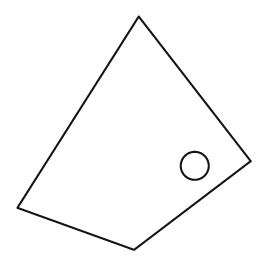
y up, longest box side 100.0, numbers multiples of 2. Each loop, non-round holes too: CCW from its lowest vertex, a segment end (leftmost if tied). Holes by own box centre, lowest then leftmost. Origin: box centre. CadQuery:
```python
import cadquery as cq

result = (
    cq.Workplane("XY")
    .moveTo(0.0, -50.0)
    .lineTo(50.0, -12.0)
    .lineTo(2.0, 50.0)
    .lineTo(-50.0, -32.0)
    .close()
    .moveTo(26.0, -14.0)
    .circle(6.0)
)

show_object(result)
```